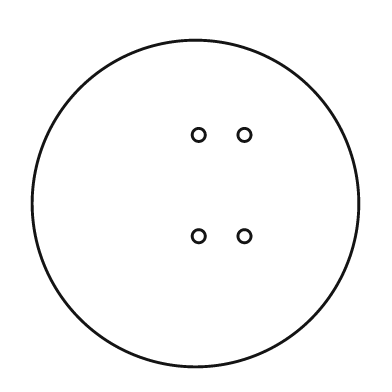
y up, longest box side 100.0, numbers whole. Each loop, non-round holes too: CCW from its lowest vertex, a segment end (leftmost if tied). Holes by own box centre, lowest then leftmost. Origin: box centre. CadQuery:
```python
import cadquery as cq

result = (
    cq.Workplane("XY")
    .moveTo(0.0, 0.0)
    .circle(50.0)
    .moveTo(1.0, -10.0)
    .circle(2.0)
    .moveTo(15.0, -10.0)
    .circle(2.0)
    .moveTo(1.0, 21.0)
    .circle(2.0)
    .moveTo(15.0, 21.0)
    .circle(2.0)
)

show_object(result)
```